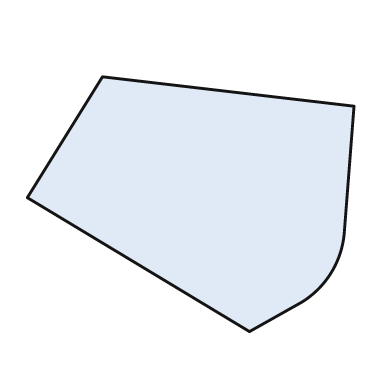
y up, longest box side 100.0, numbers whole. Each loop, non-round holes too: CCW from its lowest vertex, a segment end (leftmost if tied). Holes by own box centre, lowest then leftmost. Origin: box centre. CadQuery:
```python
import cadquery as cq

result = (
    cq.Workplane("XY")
    .moveTo(18.0, -39.0)
    .lineTo(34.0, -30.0)
    .threePointArc((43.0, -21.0), (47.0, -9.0))
    .lineTo(50.0, 30.0)
    .lineTo(-27.0, 39.0)
    .lineTo(-50.0, 2.0)
    .close()
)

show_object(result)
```